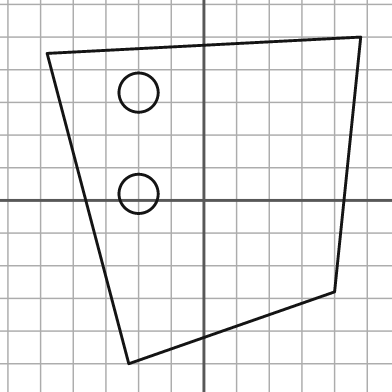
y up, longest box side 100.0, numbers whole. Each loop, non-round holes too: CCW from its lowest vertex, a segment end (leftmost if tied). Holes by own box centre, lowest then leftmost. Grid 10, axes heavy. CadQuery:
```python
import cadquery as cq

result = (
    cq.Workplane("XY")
    .moveTo(-23.0, -50.0)
    .lineTo(40.0, -28.0)
    .lineTo(48.0, 50.0)
    .lineTo(-48.0, 45.0)
    .close()
    .moveTo(-20.0, 2.0)
    .circle(6.0)
    .moveTo(-20.0, 33.0)
    .circle(6.0)
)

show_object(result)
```